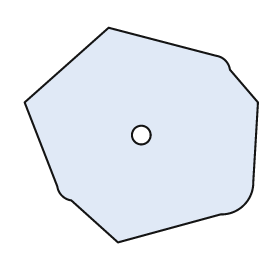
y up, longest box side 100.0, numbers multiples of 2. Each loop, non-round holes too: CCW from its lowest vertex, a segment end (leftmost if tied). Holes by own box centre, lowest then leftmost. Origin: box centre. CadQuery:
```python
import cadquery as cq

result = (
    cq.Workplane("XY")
    .moveTo(-10.0, -46.0)
    .lineTo(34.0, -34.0)
    .threePointArc((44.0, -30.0), (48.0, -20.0))
    .lineTo(50.0, 14.0)
    .lineTo(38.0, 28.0)
    .threePointArc((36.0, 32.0), (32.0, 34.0))
    .lineTo(-14.0, 46.0)
    .lineTo(-50.0, 14.0)
    .lineTo(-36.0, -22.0)
    .threePointArc((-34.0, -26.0), (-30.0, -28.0))
    .close()
    .moveTo(0.0, 0.0)
    .circle(4.0)
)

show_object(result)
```